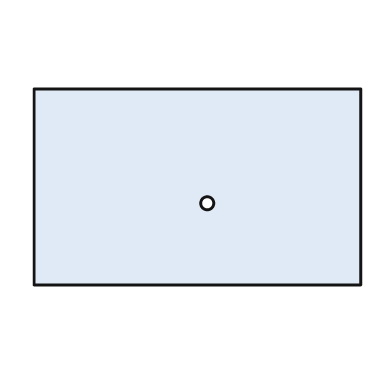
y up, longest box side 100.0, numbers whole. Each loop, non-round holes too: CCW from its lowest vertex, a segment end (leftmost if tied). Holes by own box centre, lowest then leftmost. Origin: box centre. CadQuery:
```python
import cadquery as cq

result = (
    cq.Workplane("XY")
    .moveTo(-50.0, -30.0)
    .lineTo(50.0, -30.0)
    .lineTo(50.0, 30.0)
    .lineTo(-50.0, 30.0)
    .close()
    .moveTo(3.0, -5.0)
    .circle(2.0)
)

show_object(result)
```